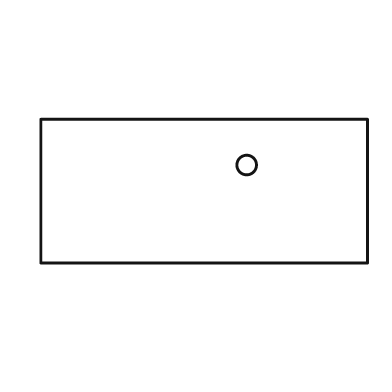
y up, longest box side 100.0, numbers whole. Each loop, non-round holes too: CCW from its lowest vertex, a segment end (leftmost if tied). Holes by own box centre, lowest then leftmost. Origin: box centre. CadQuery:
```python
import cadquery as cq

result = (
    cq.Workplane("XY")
    .moveTo(-50.0, -22.0)
    .lineTo(50.0, -22.0)
    .lineTo(50.0, 22.0)
    .lineTo(-50.0, 22.0)
    .close()
    .moveTo(13.0, 8.0)
    .circle(3.0)
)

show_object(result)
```